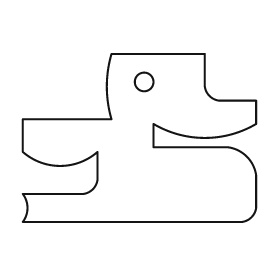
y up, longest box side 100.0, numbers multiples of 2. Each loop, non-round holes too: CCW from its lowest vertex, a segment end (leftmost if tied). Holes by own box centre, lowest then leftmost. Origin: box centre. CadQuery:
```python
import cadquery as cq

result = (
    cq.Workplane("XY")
    .moveTo(-50.0, -36.0)
    .lineTo(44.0, -36.0)
    .threePointArc((48.0, -34.0), (50.0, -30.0))
    .lineTo(50.0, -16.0)
    .threePointArc((46.0, -8.0), (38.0, -4.0))
    .lineTo(6.0, -4.0)
    .lineTo(6.0, 6.0)
    .threePointArc((28.0, 0.0), (50.0, 6.0))
    .lineTo(50.0, 16.0)
    .lineTo(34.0, 16.0)
    .threePointArc((30.0, 18.0), (28.0, 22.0))
    .lineTo(28.0, 36.0)
    .lineTo(-12.0, 36.0)
    .threePointArc((-14.0, 22.0), (-12.0, 8.0))
    .lineTo(-50.0, 8.0)
    .lineTo(-50.0, -6.0)
    .threePointArc((-34.0, -12.0), (-18.0, -6.0))
    .lineTo(-18.0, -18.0)
    .threePointArc((-20.0, -22.0), (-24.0, -24.0))
    .lineTo(-50.0, -24.0)
    .threePointArc((-48.0, -30.0), (-50.0, -36.0))
    .close()
    .moveTo(2.0, 24.0)
    .circle(4.0)
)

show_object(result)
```